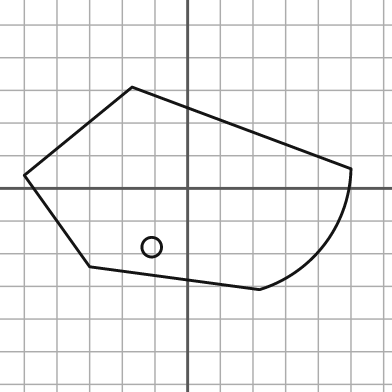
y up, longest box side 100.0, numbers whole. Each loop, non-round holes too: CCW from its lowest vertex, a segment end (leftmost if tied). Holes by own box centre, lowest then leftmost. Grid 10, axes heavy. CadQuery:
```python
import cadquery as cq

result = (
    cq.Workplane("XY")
    .moveTo(22.0, -31.0)
    .threePointArc((42.0, -17.0), (50.0, 6.0))
    .lineTo(-17.0, 31.0)
    .lineTo(-50.0, 4.0)
    .lineTo(-30.0, -24.0)
    .close()
    .moveTo(-11.0, -18.0)
    .circle(3.0)
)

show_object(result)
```